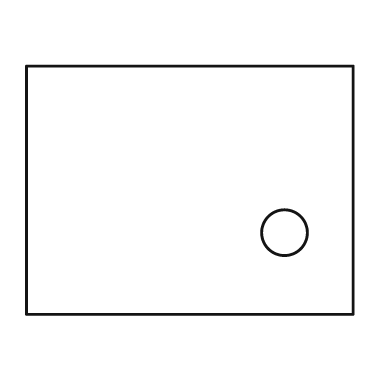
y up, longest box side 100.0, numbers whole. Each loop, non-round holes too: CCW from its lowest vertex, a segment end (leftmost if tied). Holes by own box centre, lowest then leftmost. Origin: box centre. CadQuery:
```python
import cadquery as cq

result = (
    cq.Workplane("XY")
    .moveTo(-50.0, -38.0)
    .lineTo(50.0, -38.0)
    .lineTo(50.0, 38.0)
    .lineTo(-50.0, 38.0)
    .close()
    .moveTo(29.0, -13.0)
    .circle(7.0)
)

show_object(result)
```